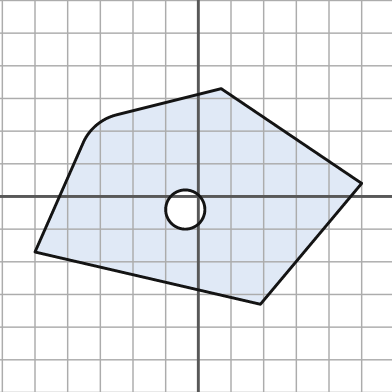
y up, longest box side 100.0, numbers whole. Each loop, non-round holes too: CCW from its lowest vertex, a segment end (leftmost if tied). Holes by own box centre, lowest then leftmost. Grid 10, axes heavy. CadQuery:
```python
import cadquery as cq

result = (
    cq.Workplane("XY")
    .moveTo(19.0, -33.0)
    .lineTo(50.0, 4.0)
    .lineTo(7.0, 33.0)
    .lineTo(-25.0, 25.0)
    .threePointArc((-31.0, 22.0), (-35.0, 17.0))
    .lineTo(-50.0, -17.0)
    .close()
    .moveTo(-4.0, -4.0)
    .circle(6.0)
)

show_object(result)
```